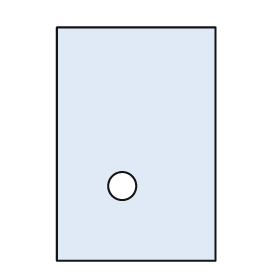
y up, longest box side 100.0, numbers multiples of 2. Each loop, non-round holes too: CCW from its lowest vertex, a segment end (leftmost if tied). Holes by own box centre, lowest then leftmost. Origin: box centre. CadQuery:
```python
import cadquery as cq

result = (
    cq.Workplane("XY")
    .moveTo(-34.0, -50.0)
    .lineTo(34.0, -50.0)
    .lineTo(34.0, 50.0)
    .lineTo(-34.0, 50.0)
    .close()
    .moveTo(-6.0, -18.0)
    .circle(6.0)
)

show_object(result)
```